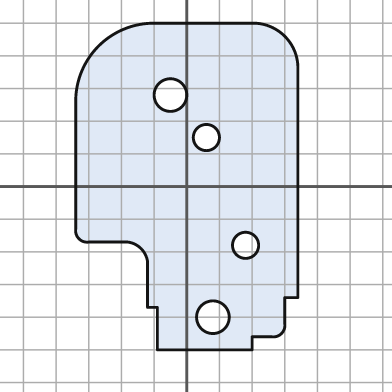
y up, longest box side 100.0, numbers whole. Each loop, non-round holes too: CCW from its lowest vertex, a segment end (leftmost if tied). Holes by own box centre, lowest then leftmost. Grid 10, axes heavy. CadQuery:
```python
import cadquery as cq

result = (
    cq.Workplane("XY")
    .moveTo(-9.0, -50.0)
    .lineTo(20.0, -50.0)
    .lineTo(20.0, -46.0)
    .lineTo(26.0, -46.0)
    .threePointArc((29.0, -45.0), (30.0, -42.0))
    .lineTo(30.0, -34.0)
    .lineTo(34.0, -34.0)
    .lineTo(34.0, 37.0)
    .threePointArc((30.0, 46.0), (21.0, 50.0))
    .lineTo(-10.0, 50.0)
    .threePointArc((-27.0, 43.0), (-34.0, 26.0))
    .lineTo(-34.0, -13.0)
    .threePointArc((-33.0, -16.0), (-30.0, -17.0))
    .lineTo(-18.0, -17.0)
    .threePointArc((-14.0, -19.0), (-12.0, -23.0))
    .lineTo(-12.0, -37.0)
    .lineTo(-9.0, -37.0)
    .close()
    .moveTo(8.0, -40.0)
    .circle(5.0)
    .moveTo(18.0, -18.0)
    .circle(4.0)
    .moveTo(6.0, 15.0)
    .circle(4.0)
    .moveTo(-5.0, 28.0)
    .circle(5.0)
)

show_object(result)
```